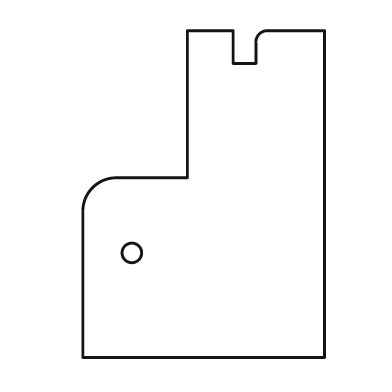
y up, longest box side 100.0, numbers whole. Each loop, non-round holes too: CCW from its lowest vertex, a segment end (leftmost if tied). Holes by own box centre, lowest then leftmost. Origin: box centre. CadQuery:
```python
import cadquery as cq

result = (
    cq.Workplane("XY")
    .moveTo(-37.0, -50.0)
    .lineTo(37.0, -50.0)
    .lineTo(37.0, 50.0)
    .lineTo(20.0, 50.0)
    .threePointArc((17.0, 49.0), (16.0, 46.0))
    .lineTo(16.0, 40.0)
    .lineTo(9.0, 40.0)
    .lineTo(9.0, 50.0)
    .lineTo(-5.0, 50.0)
    .lineTo(-5.0, 5.0)
    .lineTo(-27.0, 5.0)
    .threePointArc((-34.0, 2.0), (-37.0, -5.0))
    .close()
    .moveTo(-22.0, -18.0)
    .circle(3.0)
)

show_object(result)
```